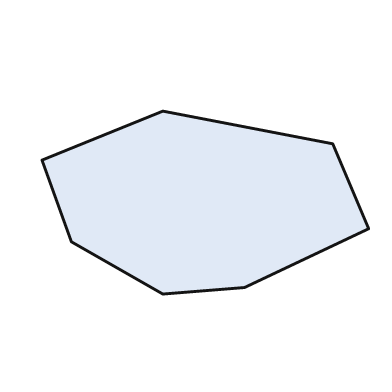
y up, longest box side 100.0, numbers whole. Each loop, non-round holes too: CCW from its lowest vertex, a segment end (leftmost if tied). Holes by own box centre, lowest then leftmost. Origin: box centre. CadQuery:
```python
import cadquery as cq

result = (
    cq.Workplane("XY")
    .moveTo(-13.0, -28.0)
    .lineTo(12.0, -26.0)
    .lineTo(50.0, -8.0)
    .lineTo(39.0, 18.0)
    .lineTo(-13.0, 28.0)
    .lineTo(-50.0, 13.0)
    .lineTo(-41.0, -12.0)
    .close()
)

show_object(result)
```